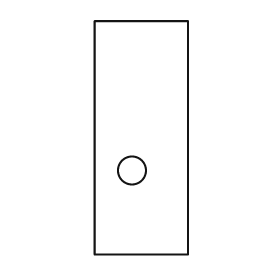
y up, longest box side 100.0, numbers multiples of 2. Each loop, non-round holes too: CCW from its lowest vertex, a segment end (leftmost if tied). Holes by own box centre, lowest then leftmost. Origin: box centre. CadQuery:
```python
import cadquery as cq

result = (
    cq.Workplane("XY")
    .moveTo(-20.0, -50.0)
    .lineTo(20.0, -50.0)
    .lineTo(20.0, 50.0)
    .lineTo(-20.0, 50.0)
    .close()
    .moveTo(-4.0, -14.0)
    .circle(6.0)
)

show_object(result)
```